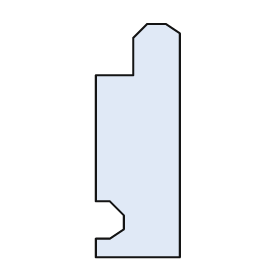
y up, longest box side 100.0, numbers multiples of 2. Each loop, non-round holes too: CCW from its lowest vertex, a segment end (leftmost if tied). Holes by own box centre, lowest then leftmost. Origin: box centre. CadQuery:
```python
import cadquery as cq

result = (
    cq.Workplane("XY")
    .moveTo(-18.0, -50.0)
    .lineTo(18.0, -50.0)
    .lineTo(18.0, 46.0)
    .lineTo(12.0, 50.0)
    .lineTo(4.0, 50.0)
    .lineTo(-2.0, 44.0)
    .lineTo(-2.0, 28.0)
    .lineTo(-18.0, 28.0)
    .lineTo(-18.0, -26.0)
    .lineTo(-12.0, -26.0)
    .lineTo(-6.0, -32.0)
    .lineTo(-6.0, -38.0)
    .lineTo(-12.0, -42.0)
    .lineTo(-18.0, -42.0)
    .close()
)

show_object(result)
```